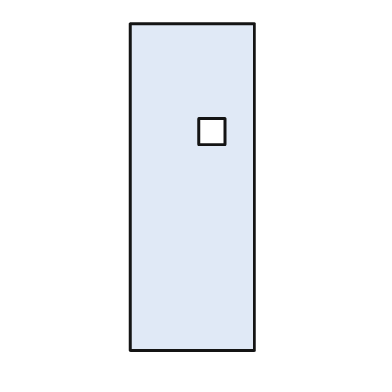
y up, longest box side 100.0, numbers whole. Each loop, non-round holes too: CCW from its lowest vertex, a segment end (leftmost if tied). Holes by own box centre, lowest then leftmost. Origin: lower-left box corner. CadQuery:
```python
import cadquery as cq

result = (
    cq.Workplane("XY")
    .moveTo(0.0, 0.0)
    .lineTo(38.0, 0.0)
    .lineTo(38.0, 100.0)
    .lineTo(0.0, 100.0)
    .close()
    .moveTo(21.0, 63.0)
    .lineTo(29.0, 63.0)
    .lineTo(29.0, 71.0)
    .lineTo(21.0, 71.0)
    .close()
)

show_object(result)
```